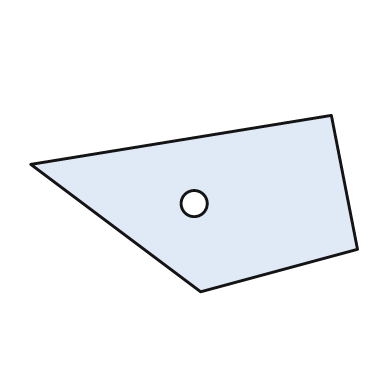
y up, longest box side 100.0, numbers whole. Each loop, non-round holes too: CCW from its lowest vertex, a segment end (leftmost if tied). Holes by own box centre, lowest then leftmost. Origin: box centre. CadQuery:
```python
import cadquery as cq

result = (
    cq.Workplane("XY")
    .moveTo(2.0, -27.0)
    .lineTo(50.0, -14.0)
    .lineTo(42.0, 27.0)
    .lineTo(-50.0, 12.0)
    .close()
    .moveTo(0.0, 0.0)
    .circle(4.0)
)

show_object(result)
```